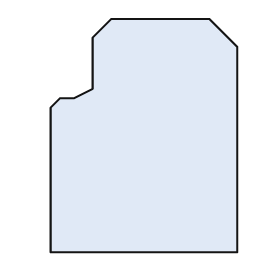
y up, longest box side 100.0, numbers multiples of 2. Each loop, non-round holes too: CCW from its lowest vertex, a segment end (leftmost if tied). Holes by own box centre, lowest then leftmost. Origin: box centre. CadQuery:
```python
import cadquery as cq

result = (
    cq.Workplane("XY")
    .moveTo(-40.0, -50.0)
    .lineTo(40.0, -50.0)
    .lineTo(40.0, 38.0)
    .lineTo(28.0, 50.0)
    .lineTo(-14.0, 50.0)
    .lineTo(-22.0, 42.0)
    .lineTo(-22.0, 20.0)
    .lineTo(-30.0, 16.0)
    .lineTo(-36.0, 16.0)
    .lineTo(-40.0, 12.0)
    .close()
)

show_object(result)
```